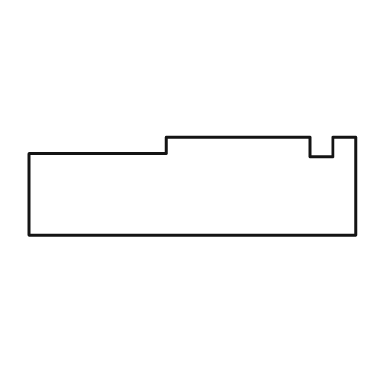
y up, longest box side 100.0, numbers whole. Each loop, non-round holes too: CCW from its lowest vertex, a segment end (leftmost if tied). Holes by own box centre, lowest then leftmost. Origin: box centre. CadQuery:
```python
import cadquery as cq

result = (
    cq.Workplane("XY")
    .moveTo(-50.0, -15.0)
    .lineTo(50.0, -15.0)
    .lineTo(50.0, 15.0)
    .lineTo(43.0, 15.0)
    .lineTo(43.0, 9.0)
    .lineTo(36.0, 9.0)
    .lineTo(36.0, 15.0)
    .lineTo(-8.0, 15.0)
    .lineTo(-8.0, 10.0)
    .lineTo(-50.0, 10.0)
    .close()
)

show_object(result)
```